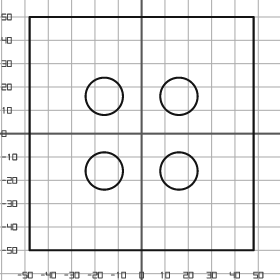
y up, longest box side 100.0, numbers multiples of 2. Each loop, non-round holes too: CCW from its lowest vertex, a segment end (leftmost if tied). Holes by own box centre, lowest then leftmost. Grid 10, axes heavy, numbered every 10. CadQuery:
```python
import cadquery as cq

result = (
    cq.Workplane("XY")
    .moveTo(-48.0, -50.0)
    .lineTo(48.0, -50.0)
    .lineTo(48.0, 50.0)
    .lineTo(-48.0, 50.0)
    .close()
    .moveTo(-16.0, -16.0)
    .circle(8.0)
    .moveTo(16.0, -16.0)
    .circle(8.0)
    .moveTo(-16.0, 16.0)
    .circle(8.0)
    .moveTo(16.0, 16.0)
    .circle(8.0)
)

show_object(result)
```